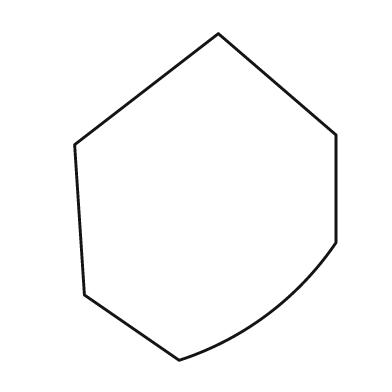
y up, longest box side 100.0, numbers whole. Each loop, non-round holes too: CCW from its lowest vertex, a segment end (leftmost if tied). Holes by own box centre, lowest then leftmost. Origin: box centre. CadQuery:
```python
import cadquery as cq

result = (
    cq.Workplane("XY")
    .moveTo(-8.0, -50.0)
    .threePointArc((19.0, -36.0), (40.0, -14.0))
    .lineTo(40.0, 19.0)
    .lineTo(4.0, 50.0)
    .lineTo(-40.0, 16.0)
    .lineTo(-37.0, -30.0)
    .close()
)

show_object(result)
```